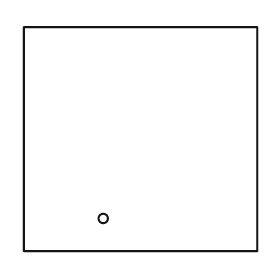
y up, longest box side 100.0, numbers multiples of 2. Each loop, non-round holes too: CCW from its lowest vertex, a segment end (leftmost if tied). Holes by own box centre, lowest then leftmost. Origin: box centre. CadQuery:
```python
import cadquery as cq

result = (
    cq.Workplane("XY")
    .moveTo(-50.0, -48.0)
    .lineTo(50.0, -48.0)
    .lineTo(50.0, 48.0)
    .lineTo(-50.0, 48.0)
    .close()
    .moveTo(-16.0, -34.0)
    .circle(2.0)
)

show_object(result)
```